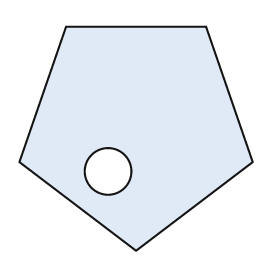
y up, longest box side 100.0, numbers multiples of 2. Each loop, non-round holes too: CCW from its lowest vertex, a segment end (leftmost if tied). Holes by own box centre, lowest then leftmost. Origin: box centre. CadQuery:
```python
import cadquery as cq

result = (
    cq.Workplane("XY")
    .moveTo(0.0, -48.0)
    .lineTo(50.0, -10.0)
    .lineTo(30.0, 48.0)
    .lineTo(-30.0, 48.0)
    .lineTo(-50.0, -10.0)
    .close()
    .moveTo(-12.0, -14.0)
    .circle(10.0)
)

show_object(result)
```